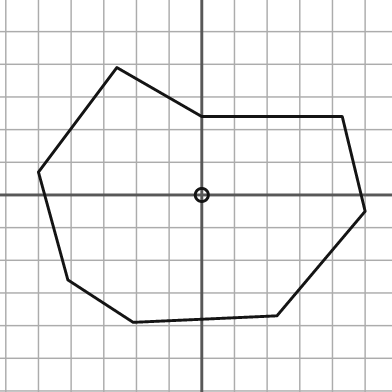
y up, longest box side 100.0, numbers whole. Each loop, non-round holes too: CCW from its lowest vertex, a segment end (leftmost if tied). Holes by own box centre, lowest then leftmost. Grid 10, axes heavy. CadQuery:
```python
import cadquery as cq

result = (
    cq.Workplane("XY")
    .moveTo(-21.0, -39.0)
    .lineTo(23.0, -37.0)
    .lineTo(50.0, -5.0)
    .lineTo(43.0, 24.0)
    .lineTo(0.0, 24.0)
    .lineTo(-26.0, 39.0)
    .lineTo(-50.0, 7.0)
    .lineTo(-41.0, -26.0)
    .close()
    .moveTo(0.0, 0.0)
    .circle(2.0)
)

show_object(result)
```